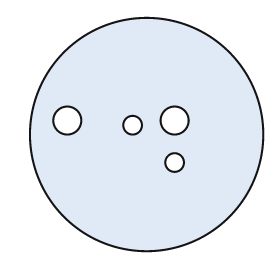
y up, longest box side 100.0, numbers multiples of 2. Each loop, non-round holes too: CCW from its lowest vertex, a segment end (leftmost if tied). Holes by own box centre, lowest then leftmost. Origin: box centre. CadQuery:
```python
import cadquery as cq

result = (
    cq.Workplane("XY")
    .moveTo(0.0, 0.0)
    .circle(50.0)
    .moveTo(12.0, -12.0)
    .circle(4.0)
    .moveTo(-6.0, 4.0)
    .circle(4.0)
    .moveTo(-34.0, 6.0)
    .circle(6.0)
    .moveTo(12.0, 6.0)
    .circle(6.0)
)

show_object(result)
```